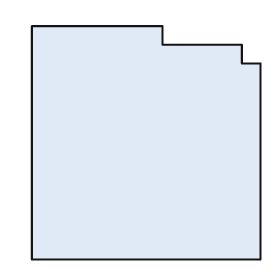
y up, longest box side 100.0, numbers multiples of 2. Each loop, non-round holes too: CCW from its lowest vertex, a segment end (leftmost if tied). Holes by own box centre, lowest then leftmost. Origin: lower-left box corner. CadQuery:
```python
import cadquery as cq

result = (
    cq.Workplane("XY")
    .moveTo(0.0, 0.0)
    .lineTo(98.0, 0.0)
    .lineTo(98.0, 84.0)
    .lineTo(90.0, 84.0)
    .lineTo(90.0, 92.0)
    .lineTo(56.0, 92.0)
    .lineTo(56.0, 100.0)
    .lineTo(0.0, 100.0)
    .close()
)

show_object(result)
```